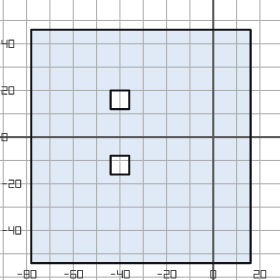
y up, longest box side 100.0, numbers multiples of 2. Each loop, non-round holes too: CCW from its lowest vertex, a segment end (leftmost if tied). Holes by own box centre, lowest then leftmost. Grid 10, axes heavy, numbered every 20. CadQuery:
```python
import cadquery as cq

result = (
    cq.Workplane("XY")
    .moveTo(-78.0, -54.0)
    .lineTo(16.0, -54.0)
    .lineTo(16.0, 46.0)
    .lineTo(-78.0, 46.0)
    .close()
    .moveTo(-44.0, -16.0)
    .lineTo(-36.0, -16.0)
    .lineTo(-36.0, -8.0)
    .lineTo(-44.0, -8.0)
    .close()
    .moveTo(-44.0, 12.0)
    .lineTo(-36.0, 12.0)
    .lineTo(-36.0, 20.0)
    .lineTo(-44.0, 20.0)
    .close()
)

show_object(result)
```